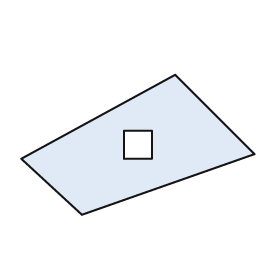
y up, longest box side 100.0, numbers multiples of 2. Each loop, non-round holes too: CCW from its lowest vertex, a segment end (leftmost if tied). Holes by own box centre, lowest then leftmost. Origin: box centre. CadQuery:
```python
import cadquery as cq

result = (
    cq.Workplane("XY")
    .moveTo(-24.0, -30.0)
    .lineTo(50.0, -4.0)
    .lineTo(16.0, 30.0)
    .lineTo(-50.0, -6.0)
    .close()
    .moveTo(-6.0, -6.0)
    .lineTo(6.0, -6.0)
    .lineTo(6.0, 6.0)
    .lineTo(-6.0, 6.0)
    .close()
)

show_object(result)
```